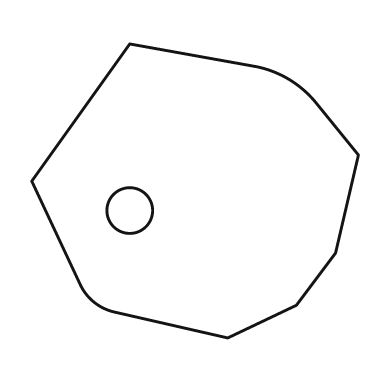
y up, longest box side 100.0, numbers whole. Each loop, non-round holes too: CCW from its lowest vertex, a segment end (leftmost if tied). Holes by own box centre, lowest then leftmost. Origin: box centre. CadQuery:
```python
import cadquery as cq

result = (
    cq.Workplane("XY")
    .moveTo(10.0, -45.0)
    .lineTo(31.0, -35.0)
    .lineTo(43.0, -19.0)
    .lineTo(50.0, 11.0)
    .lineTo(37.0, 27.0)
    .threePointArc((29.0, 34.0), (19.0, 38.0))
    .lineTo(-20.0, 45.0)
    .lineTo(-50.0, 3.0)
    .lineTo(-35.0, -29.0)
    .threePointArc((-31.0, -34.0), (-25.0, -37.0))
    .close()
    .moveTo(-20.0, -6.0)
    .circle(7.0)
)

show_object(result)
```